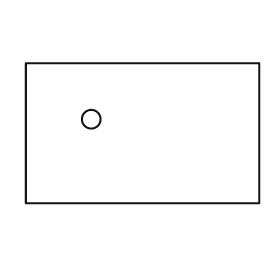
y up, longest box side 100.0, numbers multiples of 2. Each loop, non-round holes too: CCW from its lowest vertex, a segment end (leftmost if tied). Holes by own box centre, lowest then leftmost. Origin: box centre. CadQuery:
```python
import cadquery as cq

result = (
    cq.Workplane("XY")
    .moveTo(-50.0, -30.0)
    .lineTo(50.0, -30.0)
    .lineTo(50.0, 30.0)
    .lineTo(-50.0, 30.0)
    .close()
    .moveTo(-22.0, 6.0)
    .circle(4.0)
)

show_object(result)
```